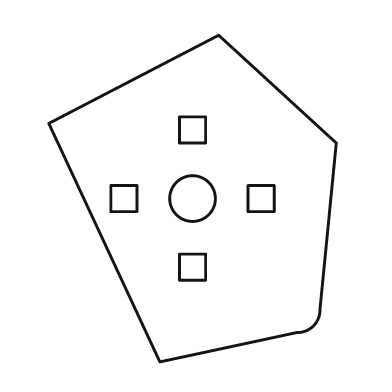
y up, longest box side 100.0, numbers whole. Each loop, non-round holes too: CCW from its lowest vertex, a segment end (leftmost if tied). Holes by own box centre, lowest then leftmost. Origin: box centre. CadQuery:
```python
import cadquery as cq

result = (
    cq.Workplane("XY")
    .moveTo(-10.0, -50.0)
    .lineTo(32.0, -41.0)
    .threePointArc((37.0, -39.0), (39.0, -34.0))
    .lineTo(44.0, 17.0)
    .lineTo(8.0, 50.0)
    .lineTo(-44.0, 23.0)
    .close()
    .moveTo(-4.0, -25.0)
    .lineTo(4.0, -25.0)
    .lineTo(4.0, -17.0)
    .lineTo(-4.0, -17.0)
    .close()
    .moveTo(-25.0, -4.0)
    .lineTo(-17.0, -4.0)
    .lineTo(-17.0, 4.0)
    .lineTo(-25.0, 4.0)
    .close()
    .moveTo(0.0, 0.0)
    .circle(7.0)
    .moveTo(17.0, -4.0)
    .lineTo(25.0, -4.0)
    .lineTo(25.0, 4.0)
    .lineTo(17.0, 4.0)
    .close()
    .moveTo(-4.0, 17.0)
    .lineTo(4.0, 17.0)
    .lineTo(4.0, 25.0)
    .lineTo(-4.0, 25.0)
    .close()
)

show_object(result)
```